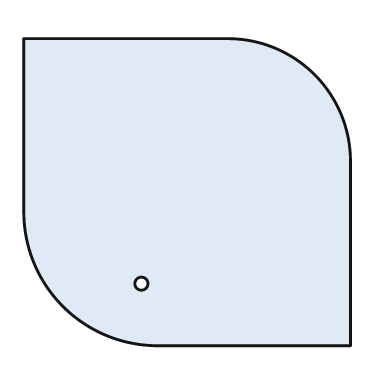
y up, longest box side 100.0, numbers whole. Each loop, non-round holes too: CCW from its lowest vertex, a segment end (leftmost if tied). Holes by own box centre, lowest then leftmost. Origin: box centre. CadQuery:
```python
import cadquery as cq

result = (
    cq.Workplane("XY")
    .moveTo(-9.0, -47.0)
    .lineTo(50.0, -47.0)
    .lineTo(50.0, 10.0)
    .threePointArc((39.0, 36.0), (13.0, 47.0))
    .lineTo(-50.0, 47.0)
    .lineTo(-50.0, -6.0)
    .threePointArc((-38.0, -35.0), (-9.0, -47.0))
    .close()
    .moveTo(-14.0, -28.0)
    .circle(2.0)
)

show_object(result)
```